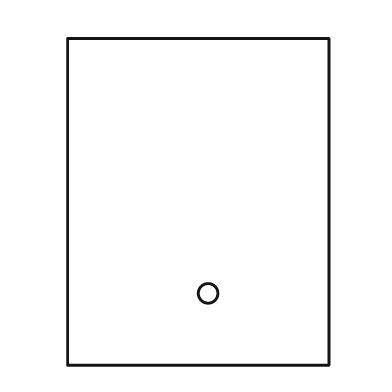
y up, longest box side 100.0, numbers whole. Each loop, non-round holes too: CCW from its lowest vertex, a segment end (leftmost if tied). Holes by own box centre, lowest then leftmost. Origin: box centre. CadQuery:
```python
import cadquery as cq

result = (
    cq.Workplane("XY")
    .moveTo(-40.0, -50.0)
    .lineTo(40.0, -50.0)
    .lineTo(40.0, 50.0)
    .lineTo(-40.0, 50.0)
    .close()
    .moveTo(3.0, -28.0)
    .circle(3.0)
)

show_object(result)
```